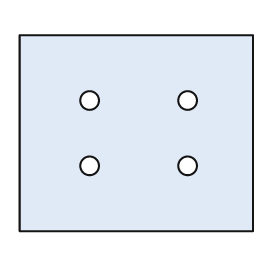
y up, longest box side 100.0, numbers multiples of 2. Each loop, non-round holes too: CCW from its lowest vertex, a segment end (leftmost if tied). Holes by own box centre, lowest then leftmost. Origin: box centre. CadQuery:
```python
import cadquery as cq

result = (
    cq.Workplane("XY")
    .moveTo(-50.0, -42.0)
    .lineTo(50.0, -42.0)
    .lineTo(50.0, 42.0)
    .lineTo(-50.0, 42.0)
    .close()
    .moveTo(-20.0, -14.0)
    .circle(4.0)
    .moveTo(22.0, -14.0)
    .circle(4.0)
    .moveTo(-20.0, 14.0)
    .circle(4.0)
    .moveTo(22.0, 14.0)
    .circle(4.0)
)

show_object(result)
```